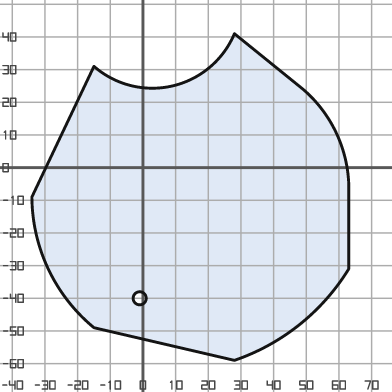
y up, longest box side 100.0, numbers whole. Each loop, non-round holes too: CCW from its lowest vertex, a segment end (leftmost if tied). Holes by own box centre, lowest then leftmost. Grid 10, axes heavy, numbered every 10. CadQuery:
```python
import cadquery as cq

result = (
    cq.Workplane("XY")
    .moveTo(28.0, -59.0)
    .threePointArc((48.0, -48.0), (63.0, -31.0))
    .lineTo(63.0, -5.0)
    .threePointArc((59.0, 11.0), (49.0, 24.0))
    .lineTo(28.0, 41.0)
    .threePointArc((9.0, 25.0), (-15.0, 31.0))
    .lineTo(-34.0, -9.0)
    .threePointArc((-29.0, -31.0), (-15.0, -49.0))
    .close()
    .moveTo(-1.0, -40.0)
    .circle(2.0)
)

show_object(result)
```